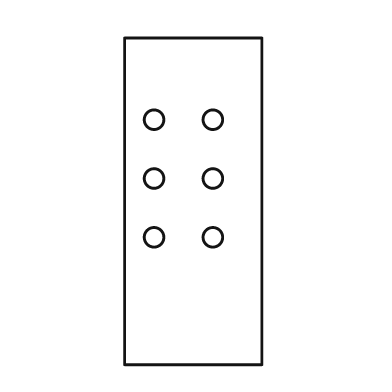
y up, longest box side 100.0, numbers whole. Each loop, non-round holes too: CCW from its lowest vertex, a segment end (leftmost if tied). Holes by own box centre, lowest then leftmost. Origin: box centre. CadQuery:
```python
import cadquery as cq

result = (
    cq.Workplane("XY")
    .moveTo(-21.0, -50.0)
    .lineTo(21.0, -50.0)
    .lineTo(21.0, 50.0)
    .lineTo(-21.0, 50.0)
    .close()
    .moveTo(-12.0, -11.0)
    .circle(3.0)
    .moveTo(6.0, -11.0)
    .circle(3.0)
    .moveTo(-12.0, 7.0)
    .circle(3.0)
    .moveTo(6.0, 7.0)
    .circle(3.0)
    .moveTo(-12.0, 25.0)
    .circle(3.0)
    .moveTo(6.0, 25.0)
    .circle(3.0)
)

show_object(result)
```